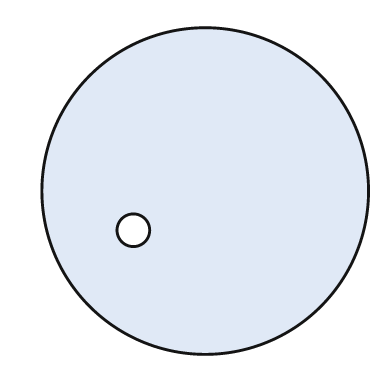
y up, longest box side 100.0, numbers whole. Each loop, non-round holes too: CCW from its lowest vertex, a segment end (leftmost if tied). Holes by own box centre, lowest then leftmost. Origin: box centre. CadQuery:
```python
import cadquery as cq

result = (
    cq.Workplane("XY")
    .moveTo(0.0, 0.0)
    .circle(50.0)
    .moveTo(-22.0, -12.0)
    .circle(5.0)
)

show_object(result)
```